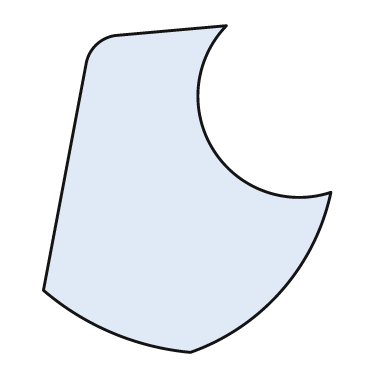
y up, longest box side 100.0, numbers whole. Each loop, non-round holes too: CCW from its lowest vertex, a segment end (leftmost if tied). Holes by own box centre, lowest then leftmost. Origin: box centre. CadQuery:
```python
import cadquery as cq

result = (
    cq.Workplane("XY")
    .moveTo(1.0, -50.0)
    .threePointArc((29.0, -31.0), (44.0, -1.0))
    .threePointArc((8.0, 12.0), (12.0, 50.0))
    .lineTo(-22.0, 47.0)
    .threePointArc((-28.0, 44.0), (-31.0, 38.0))
    .lineTo(-44.0, -31.0)
    .threePointArc((-23.0, -44.0), (1.0, -50.0))
    .close()
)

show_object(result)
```